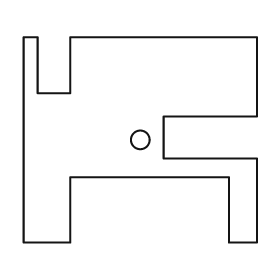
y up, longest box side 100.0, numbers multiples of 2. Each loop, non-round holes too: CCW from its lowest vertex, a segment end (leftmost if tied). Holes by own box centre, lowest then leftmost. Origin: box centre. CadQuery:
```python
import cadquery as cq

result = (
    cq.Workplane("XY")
    .moveTo(-50.0, -44.0)
    .lineTo(-30.0, -44.0)
    .lineTo(-30.0, -16.0)
    .lineTo(38.0, -16.0)
    .lineTo(38.0, -44.0)
    .lineTo(50.0, -44.0)
    .lineTo(50.0, -8.0)
    .lineTo(10.0, -8.0)
    .lineTo(10.0, 10.0)
    .lineTo(50.0, 10.0)
    .lineTo(50.0, 44.0)
    .lineTo(-30.0, 44.0)
    .lineTo(-30.0, 20.0)
    .lineTo(-44.0, 20.0)
    .lineTo(-44.0, 44.0)
    .lineTo(-50.0, 44.0)
    .close()
    .moveTo(0.0, 0.0)
    .circle(4.0)
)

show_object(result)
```